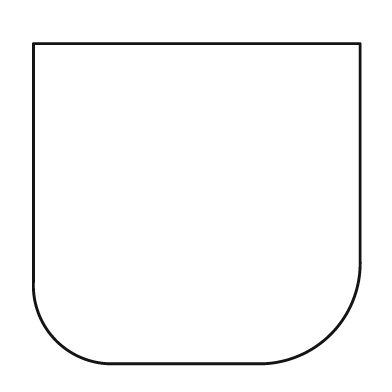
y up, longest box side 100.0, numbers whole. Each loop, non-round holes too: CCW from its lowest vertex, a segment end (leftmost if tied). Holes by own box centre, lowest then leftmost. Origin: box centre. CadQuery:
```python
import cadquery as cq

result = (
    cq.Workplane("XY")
    .moveTo(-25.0, -49.0)
    .lineTo(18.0, -49.0)
    .threePointArc((41.0, -40.0), (50.0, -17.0))
    .lineTo(50.0, 49.0)
    .lineTo(-50.0, 49.0)
    .lineTo(-50.0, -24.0)
    .threePointArc((-43.0, -42.0), (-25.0, -49.0))
    .close()
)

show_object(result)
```